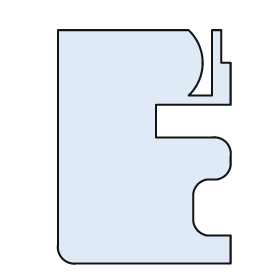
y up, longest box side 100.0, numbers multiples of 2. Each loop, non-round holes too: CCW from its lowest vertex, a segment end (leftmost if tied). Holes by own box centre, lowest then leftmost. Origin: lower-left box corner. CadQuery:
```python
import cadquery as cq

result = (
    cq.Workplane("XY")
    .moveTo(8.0, 0.0)
    .lineTo(74.0, 0.0)
    .lineTo(74.0, 12.0)
    .lineTo(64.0, 12.0)
    .threePointArc((60.0, 14.0), (58.0, 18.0))
    .lineTo(58.0, 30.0)
    .threePointArc((60.0, 34.0), (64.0, 36.0))
    .lineTo(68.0, 36.0)
    .threePointArc((72.0, 38.0), (74.0, 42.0))
    .lineTo(74.0, 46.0)
    .threePointArc((72.0, 52.0), (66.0, 54.0))
    .lineTo(42.0, 54.0)
    .lineTo(42.0, 68.0)
    .lineTo(74.0, 68.0)
    .lineTo(74.0, 86.0)
    .lineTo(70.0, 86.0)
    .lineTo(70.0, 100.0)
    .lineTo(66.0, 100.0)
    .lineTo(66.0, 72.0)
    .lineTo(56.0, 72.0)
    .threePointArc((62.0, 86.0), (56.0, 100.0))
    .lineTo(0.0, 100.0)
    .lineTo(0.0, 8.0)
    .threePointArc((2.0, 2.0), (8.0, 0.0))
    .close()
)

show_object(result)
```